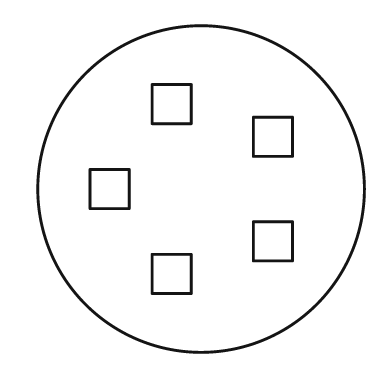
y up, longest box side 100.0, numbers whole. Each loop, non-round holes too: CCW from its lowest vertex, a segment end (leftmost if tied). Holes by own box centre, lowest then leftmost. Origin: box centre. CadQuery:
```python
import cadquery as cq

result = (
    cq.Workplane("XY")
    .moveTo(0.0, 0.0)
    .circle(50.0)
    .moveTo(-15.0, -32.0)
    .lineTo(-3.0, -32.0)
    .lineTo(-3.0, -20.0)
    .lineTo(-15.0, -20.0)
    .close()
    .moveTo(16.0, -22.0)
    .lineTo(28.0, -22.0)
    .lineTo(28.0, -10.0)
    .lineTo(16.0, -10.0)
    .close()
    .moveTo(-34.0, -6.0)
    .lineTo(-22.0, -6.0)
    .lineTo(-22.0, 6.0)
    .lineTo(-34.0, 6.0)
    .close()
    .moveTo(16.0, 10.0)
    .lineTo(28.0, 10.0)
    .lineTo(28.0, 22.0)
    .lineTo(16.0, 22.0)
    .close()
    .moveTo(-15.0, 20.0)
    .lineTo(-3.0, 20.0)
    .lineTo(-3.0, 32.0)
    .lineTo(-15.0, 32.0)
    .close()
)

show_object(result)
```